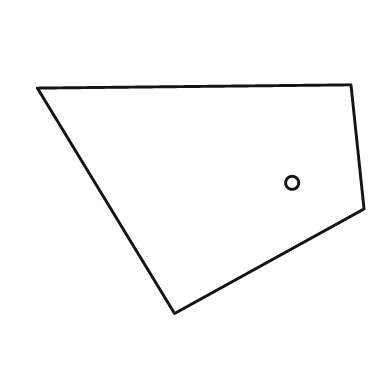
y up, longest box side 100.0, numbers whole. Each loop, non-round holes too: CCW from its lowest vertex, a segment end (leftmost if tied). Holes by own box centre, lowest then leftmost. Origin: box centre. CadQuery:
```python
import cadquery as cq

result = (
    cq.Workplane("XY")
    .moveTo(-8.0, -35.0)
    .lineTo(50.0, -3.0)
    .lineTo(46.0, 35.0)
    .lineTo(-50.0, 34.0)
    .close()
    .moveTo(28.0, 5.0)
    .circle(2.0)
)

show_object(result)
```